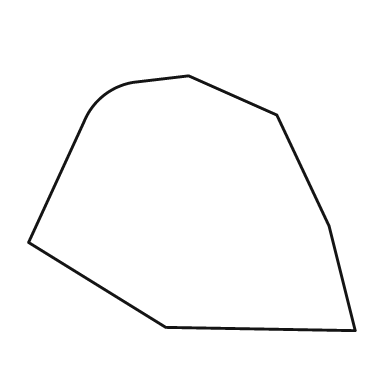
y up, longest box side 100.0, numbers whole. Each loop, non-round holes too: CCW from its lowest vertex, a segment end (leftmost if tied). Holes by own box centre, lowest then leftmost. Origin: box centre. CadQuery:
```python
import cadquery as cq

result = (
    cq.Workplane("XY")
    .moveTo(50.0, -39.0)
    .lineTo(42.0, -7.0)
    .lineTo(26.0, 27.0)
    .lineTo(-1.0, 39.0)
    .lineTo(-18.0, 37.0)
    .threePointArc((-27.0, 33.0), (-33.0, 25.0))
    .lineTo(-50.0, -12.0)
    .lineTo(-8.0, -38.0)
    .close()
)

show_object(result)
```